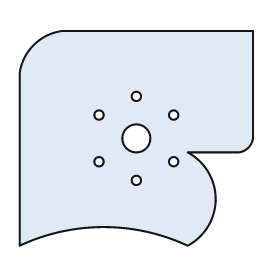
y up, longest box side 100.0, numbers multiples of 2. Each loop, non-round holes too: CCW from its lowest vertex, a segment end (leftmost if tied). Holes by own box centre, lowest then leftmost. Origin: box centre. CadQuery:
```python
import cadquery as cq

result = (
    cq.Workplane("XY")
    .moveTo(-50.0, -46.0)
    .threePointArc((-14.0, -38.0), (22.0, -46.0))
    .threePointArc((34.0, -26.0), (22.0, -6.0))
    .lineTo(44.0, -6.0)
    .threePointArc((48.0, -4.0), (50.0, 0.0))
    .lineTo(50.0, 46.0)
    .lineTo(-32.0, 46.0)
    .threePointArc((-44.0, 40.0), (-50.0, 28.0))
    .close()
    .moveTo(0.0, -18.0)
    .circle(2.0)
    .moveTo(-16.0, -10.0)
    .circle(2.0)
    .moveTo(16.0, -10.0)
    .circle(2.0)
    .moveTo(0.0, 0.0)
    .circle(6.0)
    .moveTo(-16.0, 10.0)
    .circle(2.0)
    .moveTo(16.0, 10.0)
    .circle(2.0)
    .moveTo(0.0, 18.0)
    .circle(2.0)
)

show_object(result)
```